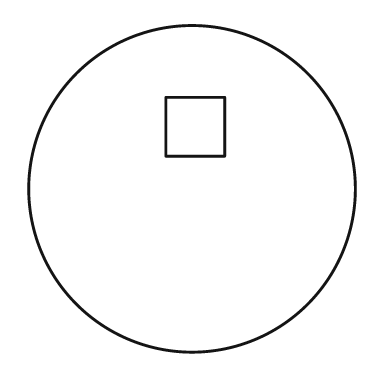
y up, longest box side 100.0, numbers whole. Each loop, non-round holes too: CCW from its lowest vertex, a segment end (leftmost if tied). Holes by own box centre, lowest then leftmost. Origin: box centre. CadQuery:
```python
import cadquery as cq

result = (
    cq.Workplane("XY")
    .moveTo(0.0, 0.0)
    .circle(50.0)
    .moveTo(-8.0, 10.0)
    .lineTo(10.0, 10.0)
    .lineTo(10.0, 28.0)
    .lineTo(-8.0, 28.0)
    .close()
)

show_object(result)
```